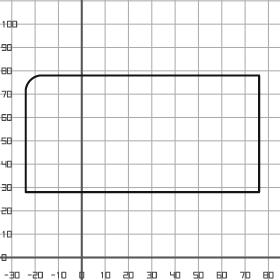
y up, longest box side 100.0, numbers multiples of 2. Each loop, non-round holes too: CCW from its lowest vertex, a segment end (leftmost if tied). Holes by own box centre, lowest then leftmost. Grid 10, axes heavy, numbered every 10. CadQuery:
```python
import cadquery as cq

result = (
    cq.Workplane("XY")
    .moveTo(-24.0, 28.0)
    .lineTo(76.0, 28.0)
    .lineTo(76.0, 78.0)
    .lineTo(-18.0, 78.0)
    .threePointArc((-22.0, 76.0), (-24.0, 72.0))
    .close()
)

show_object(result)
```